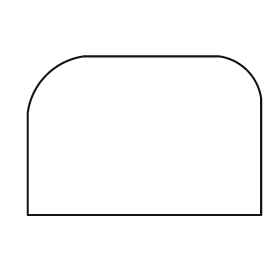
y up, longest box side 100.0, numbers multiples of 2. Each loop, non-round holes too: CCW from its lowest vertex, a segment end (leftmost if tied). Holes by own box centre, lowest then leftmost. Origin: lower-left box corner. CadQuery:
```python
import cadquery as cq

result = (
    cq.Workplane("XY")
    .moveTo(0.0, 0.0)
    .lineTo(100.0, 0.0)
    .lineTo(100.0, 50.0)
    .threePointArc((94.0, 62.0), (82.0, 68.0))
    .lineTo(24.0, 68.0)
    .threePointArc((8.0, 60.0), (0.0, 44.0))
    .close()
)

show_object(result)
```